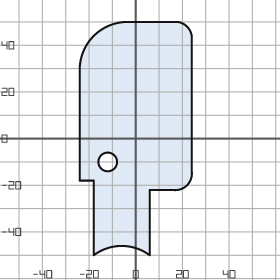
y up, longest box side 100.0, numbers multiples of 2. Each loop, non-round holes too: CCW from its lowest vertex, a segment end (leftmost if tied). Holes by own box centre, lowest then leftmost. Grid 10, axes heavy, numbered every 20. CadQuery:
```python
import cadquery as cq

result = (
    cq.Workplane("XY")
    .moveTo(-18.0, -50.0)
    .threePointArc((-6.0, -46.0), (6.0, -50.0))
    .lineTo(6.0, -22.0)
    .lineTo(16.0, -22.0)
    .threePointArc((22.0, -20.0), (24.0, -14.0))
    .lineTo(24.0, 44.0)
    .threePointArc((22.0, 48.0), (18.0, 50.0))
    .lineTo(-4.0, 50.0)
    .threePointArc((-18.0, 44.0), (-24.0, 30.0))
    .lineTo(-24.0, -18.0)
    .lineTo(-18.0, -18.0)
    .close()
    .moveTo(-12.0, -10.0)
    .circle(4.0)
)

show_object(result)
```